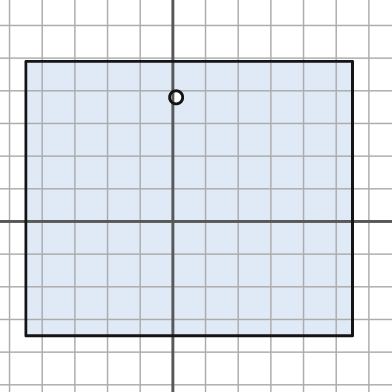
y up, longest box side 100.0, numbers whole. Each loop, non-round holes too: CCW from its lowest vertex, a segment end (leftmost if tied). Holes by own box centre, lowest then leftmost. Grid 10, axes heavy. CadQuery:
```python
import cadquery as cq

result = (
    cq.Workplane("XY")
    .moveTo(-45.0, -35.0)
    .lineTo(55.0, -35.0)
    .lineTo(55.0, 49.0)
    .lineTo(-45.0, 49.0)
    .close()
    .moveTo(1.0, 38.0)
    .circle(2.0)
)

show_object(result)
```